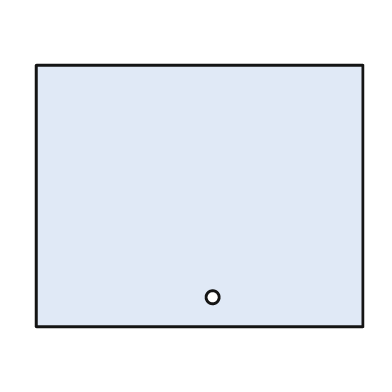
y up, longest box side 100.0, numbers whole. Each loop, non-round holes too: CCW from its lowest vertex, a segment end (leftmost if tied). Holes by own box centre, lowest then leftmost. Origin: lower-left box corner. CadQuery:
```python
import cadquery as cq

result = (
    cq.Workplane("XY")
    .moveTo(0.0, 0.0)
    .lineTo(100.0, 0.0)
    .lineTo(100.0, 80.0)
    .lineTo(0.0, 80.0)
    .close()
    .moveTo(54.0, 9.0)
    .circle(2.0)
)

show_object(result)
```